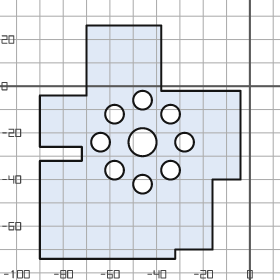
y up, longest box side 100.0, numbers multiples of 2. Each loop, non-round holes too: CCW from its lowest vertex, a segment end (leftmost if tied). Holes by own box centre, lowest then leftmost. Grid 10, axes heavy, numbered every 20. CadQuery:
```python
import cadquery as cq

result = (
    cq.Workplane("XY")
    .moveTo(-90.0, -74.0)
    .lineTo(-32.0, -74.0)
    .lineTo(-32.0, -70.0)
    .lineTo(-16.0, -70.0)
    .lineTo(-16.0, -40.0)
    .lineTo(-4.0, -40.0)
    .lineTo(-4.0, -2.0)
    .lineTo(-38.0, -2.0)
    .lineTo(-38.0, 26.0)
    .lineTo(-70.0, 26.0)
    .lineTo(-70.0, -4.0)
    .lineTo(-90.0, -4.0)
    .lineTo(-90.0, -26.0)
    .lineTo(-72.0, -26.0)
    .lineTo(-72.0, -32.0)
    .lineTo(-90.0, -32.0)
    .close()
    .moveTo(-46.0, -42.0)
    .circle(4.0)
    .moveTo(-58.0, -36.0)
    .circle(4.0)
    .moveTo(-34.0, -36.0)
    .circle(4.0)
    .moveTo(-64.0, -24.0)
    .circle(4.0)
    .moveTo(-46.0, -24.0)
    .circle(6.0)
    .moveTo(-28.0, -24.0)
    .circle(4.0)
    .moveTo(-58.0, -12.0)
    .circle(4.0)
    .moveTo(-34.0, -12.0)
    .circle(4.0)
    .moveTo(-46.0, -6.0)
    .circle(4.0)
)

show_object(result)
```